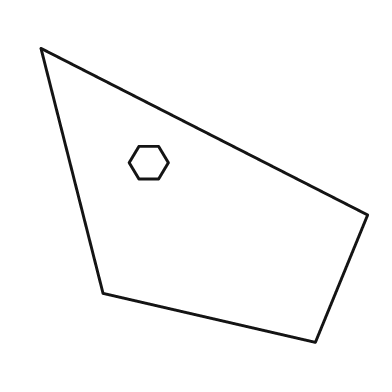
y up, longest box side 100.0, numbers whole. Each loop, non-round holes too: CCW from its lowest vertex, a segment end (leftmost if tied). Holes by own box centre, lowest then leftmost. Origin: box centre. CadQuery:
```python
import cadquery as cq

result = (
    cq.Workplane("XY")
    .moveTo(34.0, -45.0)
    .lineTo(50.0, -6.0)
    .lineTo(-50.0, 45.0)
    .lineTo(-31.0, -30.0)
    .close()
    .moveTo(-20.0, 5.0)
    .lineTo(-14.0, 5.0)
    .lineTo(-11.0, 10.0)
    .lineTo(-14.0, 15.0)
    .lineTo(-20.0, 15.0)
    .lineTo(-23.0, 10.0)
    .close()
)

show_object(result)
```